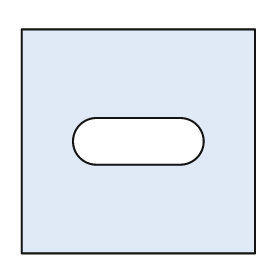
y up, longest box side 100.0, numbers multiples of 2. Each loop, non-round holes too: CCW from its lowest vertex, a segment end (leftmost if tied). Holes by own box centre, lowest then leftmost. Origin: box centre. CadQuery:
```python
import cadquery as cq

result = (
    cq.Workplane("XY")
    .moveTo(-50.0, -48.0)
    .lineTo(50.0, -48.0)
    .lineTo(50.0, 48.0)
    .lineTo(-50.0, 48.0)
    .close()
    .moveTo(-18.0, -10.0)
    .lineTo(18.0, -10.0)
    .threePointArc((28.0, 0.0), (18.0, 10.0))
    .lineTo(-18.0, 10.0)
    .threePointArc((-28.0, 0.0), (-18.0, -10.0))
    .close()
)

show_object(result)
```